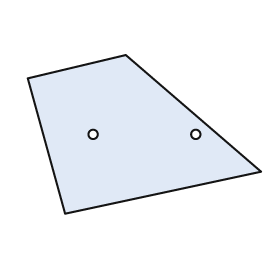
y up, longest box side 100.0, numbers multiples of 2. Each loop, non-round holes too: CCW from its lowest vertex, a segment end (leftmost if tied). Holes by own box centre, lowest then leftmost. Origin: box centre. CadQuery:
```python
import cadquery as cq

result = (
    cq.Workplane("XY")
    .moveTo(-34.0, -34.0)
    .lineTo(50.0, -16.0)
    .lineTo(-8.0, 34.0)
    .lineTo(-50.0, 24.0)
    .close()
    .moveTo(-22.0, 0.0)
    .circle(2.0)
    .moveTo(22.0, 0.0)
    .circle(2.0)
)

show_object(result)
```